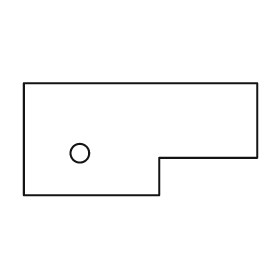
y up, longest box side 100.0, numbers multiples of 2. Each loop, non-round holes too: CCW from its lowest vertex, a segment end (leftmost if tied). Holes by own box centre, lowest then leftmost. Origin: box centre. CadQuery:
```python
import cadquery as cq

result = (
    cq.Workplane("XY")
    .moveTo(-50.0, -24.0)
    .lineTo(8.0, -24.0)
    .lineTo(8.0, -8.0)
    .lineTo(50.0, -8.0)
    .lineTo(50.0, 24.0)
    .lineTo(-50.0, 24.0)
    .close()
    .moveTo(-26.0, -6.0)
    .circle(4.0)
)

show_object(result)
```